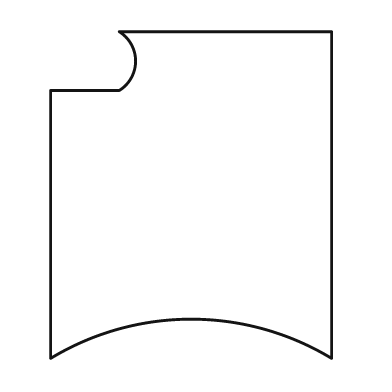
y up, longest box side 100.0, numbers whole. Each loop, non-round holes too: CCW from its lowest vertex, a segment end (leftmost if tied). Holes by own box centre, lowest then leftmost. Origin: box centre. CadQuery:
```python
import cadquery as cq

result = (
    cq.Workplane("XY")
    .moveTo(-43.0, -50.0)
    .threePointArc((0.0, -38.0), (43.0, -50.0))
    .lineTo(43.0, 50.0)
    .lineTo(-22.0, 50.0)
    .threePointArc((-17.0, 41.0), (-22.0, 32.0))
    .lineTo(-43.0, 32.0)
    .close()
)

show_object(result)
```